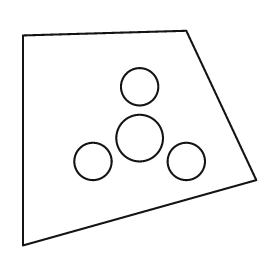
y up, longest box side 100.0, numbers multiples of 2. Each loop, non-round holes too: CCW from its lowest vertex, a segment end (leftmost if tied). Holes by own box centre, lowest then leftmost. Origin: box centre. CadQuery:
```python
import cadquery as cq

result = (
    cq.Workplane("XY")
    .moveTo(-50.0, -46.0)
    .lineTo(50.0, -18.0)
    .lineTo(20.0, 46.0)
    .lineTo(-50.0, 44.0)
    .close()
    .moveTo(-20.0, -10.0)
    .circle(8.0)
    .moveTo(20.0, -10.0)
    .circle(8.0)
    .moveTo(0.0, 0.0)
    .circle(10.0)
    .moveTo(0.0, 22.0)
    .circle(8.0)
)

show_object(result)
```